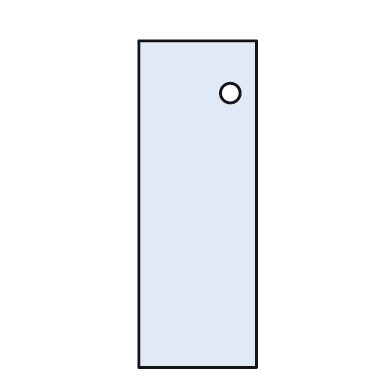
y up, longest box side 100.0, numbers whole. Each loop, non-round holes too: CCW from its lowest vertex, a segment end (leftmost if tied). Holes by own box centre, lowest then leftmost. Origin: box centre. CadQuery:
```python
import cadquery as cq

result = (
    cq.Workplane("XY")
    .moveTo(-18.0, -50.0)
    .lineTo(18.0, -50.0)
    .lineTo(18.0, 50.0)
    .lineTo(-18.0, 50.0)
    .close()
    .moveTo(10.0, 34.0)
    .circle(3.0)
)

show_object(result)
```